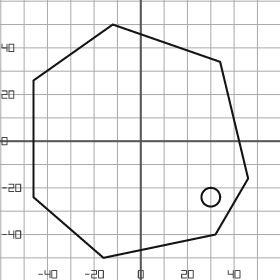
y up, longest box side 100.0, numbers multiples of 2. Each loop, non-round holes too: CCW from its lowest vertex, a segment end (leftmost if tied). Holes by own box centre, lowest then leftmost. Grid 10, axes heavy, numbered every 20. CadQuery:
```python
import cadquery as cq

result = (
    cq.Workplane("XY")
    .moveTo(-16.0, -50.0)
    .lineTo(32.0, -40.0)
    .lineTo(46.0, -16.0)
    .lineTo(34.0, 34.0)
    .lineTo(-12.0, 50.0)
    .lineTo(-46.0, 26.0)
    .lineTo(-46.0, -24.0)
    .close()
    .moveTo(30.0, -24.0)
    .circle(4.0)
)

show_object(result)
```